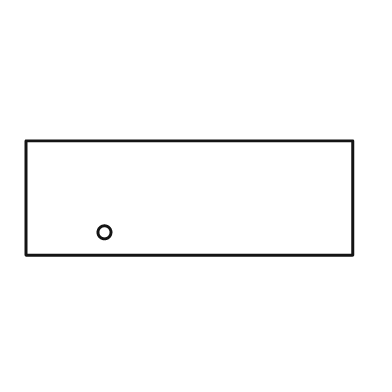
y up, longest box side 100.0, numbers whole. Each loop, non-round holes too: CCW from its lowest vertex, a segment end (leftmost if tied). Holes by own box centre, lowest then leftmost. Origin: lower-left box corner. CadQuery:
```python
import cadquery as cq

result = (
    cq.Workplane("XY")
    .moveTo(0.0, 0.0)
    .lineTo(100.0, 0.0)
    .lineTo(100.0, 35.0)
    .lineTo(0.0, 35.0)
    .close()
    .moveTo(24.0, 7.0)
    .circle(2.0)
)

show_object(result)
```